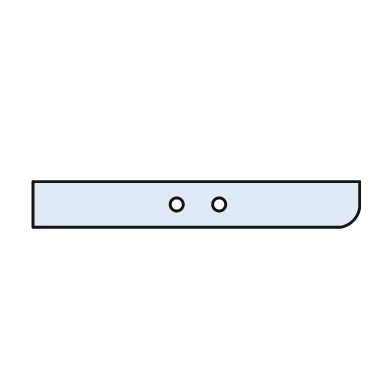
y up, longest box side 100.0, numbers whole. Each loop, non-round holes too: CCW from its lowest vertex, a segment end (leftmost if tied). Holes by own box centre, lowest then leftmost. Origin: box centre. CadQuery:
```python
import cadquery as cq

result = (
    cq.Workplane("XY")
    .moveTo(-50.0, -7.0)
    .lineTo(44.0, -7.0)
    .threePointArc((48.0, -5.0), (50.0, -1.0))
    .lineTo(50.0, 7.0)
    .lineTo(-50.0, 7.0)
    .close()
    .moveTo(-6.0, 0.0)
    .circle(2.0)
    .moveTo(7.0, 0.0)
    .circle(2.0)
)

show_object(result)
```